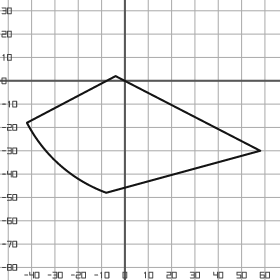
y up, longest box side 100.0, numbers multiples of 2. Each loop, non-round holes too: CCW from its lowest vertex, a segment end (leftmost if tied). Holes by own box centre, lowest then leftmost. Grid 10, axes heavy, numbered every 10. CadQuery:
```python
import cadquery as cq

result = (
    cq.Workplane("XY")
    .moveTo(-8.0, -48.0)
    .lineTo(58.0, -30.0)
    .lineTo(-4.0, 2.0)
    .lineTo(-42.0, -18.0)
    .threePointArc((-28.0, -36.0), (-8.0, -48.0))
    .close()
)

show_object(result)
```